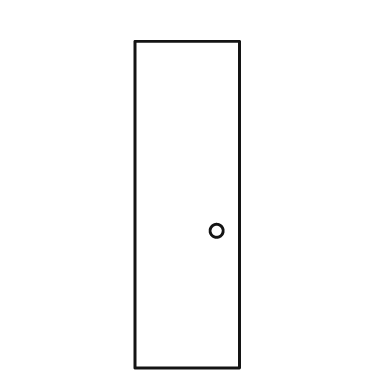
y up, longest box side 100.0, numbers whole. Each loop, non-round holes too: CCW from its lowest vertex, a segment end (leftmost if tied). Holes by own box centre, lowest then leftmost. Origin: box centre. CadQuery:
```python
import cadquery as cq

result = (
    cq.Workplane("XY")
    .moveTo(-16.0, -50.0)
    .lineTo(16.0, -50.0)
    .lineTo(16.0, 50.0)
    .lineTo(-16.0, 50.0)
    .close()
    .moveTo(9.0, -8.0)
    .circle(2.0)
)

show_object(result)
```